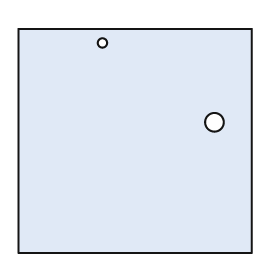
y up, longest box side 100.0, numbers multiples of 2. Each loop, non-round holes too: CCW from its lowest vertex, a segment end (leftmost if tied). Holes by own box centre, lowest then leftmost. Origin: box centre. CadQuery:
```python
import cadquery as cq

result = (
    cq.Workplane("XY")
    .moveTo(-50.0, -48.0)
    .lineTo(50.0, -48.0)
    .lineTo(50.0, 48.0)
    .lineTo(-50.0, 48.0)
    .close()
    .moveTo(34.0, 8.0)
    .circle(4.0)
    .moveTo(-14.0, 42.0)
    .circle(2.0)
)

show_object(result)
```